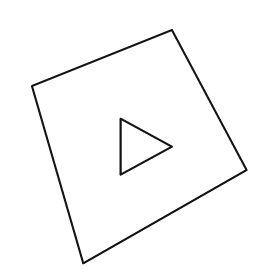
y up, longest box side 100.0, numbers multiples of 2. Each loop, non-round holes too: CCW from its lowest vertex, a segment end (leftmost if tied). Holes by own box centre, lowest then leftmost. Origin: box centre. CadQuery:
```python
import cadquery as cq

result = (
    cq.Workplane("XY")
    .moveTo(-24.0, -50.0)
    .lineTo(46.0, -10.0)
    .lineTo(14.0, 50.0)
    .lineTo(-46.0, 26.0)
    .close()
    .moveTo(-8.0, -12.0)
    .lineTo(14.0, 0.0)
    .lineTo(-8.0, 12.0)
    .close()
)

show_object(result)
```